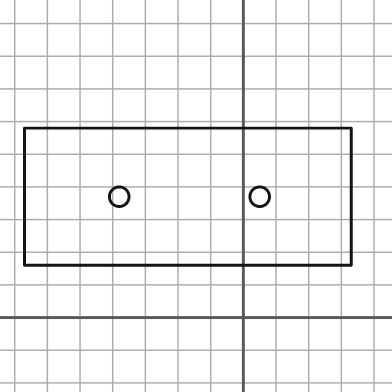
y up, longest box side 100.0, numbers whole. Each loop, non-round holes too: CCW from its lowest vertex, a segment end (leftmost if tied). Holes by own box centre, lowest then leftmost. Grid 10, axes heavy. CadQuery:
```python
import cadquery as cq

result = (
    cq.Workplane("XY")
    .moveTo(-67.0, 16.0)
    .lineTo(33.0, 16.0)
    .lineTo(33.0, 58.0)
    .lineTo(-67.0, 58.0)
    .close()
    .moveTo(-38.0, 37.0)
    .circle(3.0)
    .moveTo(5.0, 37.0)
    .circle(3.0)
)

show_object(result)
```